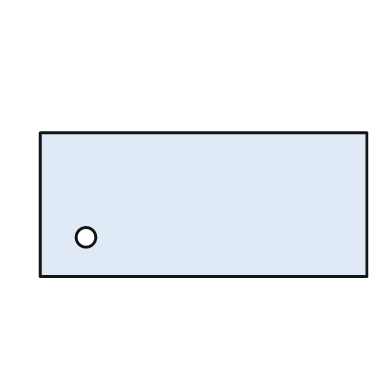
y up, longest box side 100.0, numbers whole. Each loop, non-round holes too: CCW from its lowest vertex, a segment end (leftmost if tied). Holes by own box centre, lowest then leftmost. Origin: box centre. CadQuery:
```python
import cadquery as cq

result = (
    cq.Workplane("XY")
    .moveTo(-50.0, -22.0)
    .lineTo(50.0, -22.0)
    .lineTo(50.0, 22.0)
    .lineTo(-50.0, 22.0)
    .close()
    .moveTo(-36.0, -10.0)
    .circle(3.0)
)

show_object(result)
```